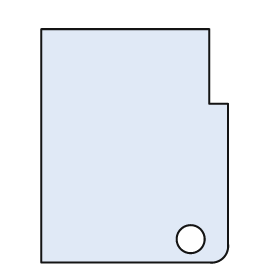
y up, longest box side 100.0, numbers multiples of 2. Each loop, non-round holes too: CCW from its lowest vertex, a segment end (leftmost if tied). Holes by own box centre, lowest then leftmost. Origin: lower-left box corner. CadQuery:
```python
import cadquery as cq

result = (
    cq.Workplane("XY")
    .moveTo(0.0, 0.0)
    .lineTo(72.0, 0.0)
    .threePointArc((78.0, 2.0), (80.0, 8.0))
    .lineTo(80.0, 68.0)
    .lineTo(72.0, 68.0)
    .lineTo(72.0, 100.0)
    .lineTo(0.0, 100.0)
    .close()
    .moveTo(64.0, 10.0)
    .circle(6.0)
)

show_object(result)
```